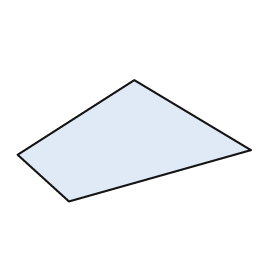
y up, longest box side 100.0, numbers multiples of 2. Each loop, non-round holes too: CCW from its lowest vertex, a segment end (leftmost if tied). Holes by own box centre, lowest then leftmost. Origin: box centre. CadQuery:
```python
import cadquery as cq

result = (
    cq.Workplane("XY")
    .moveTo(-28.0, -26.0)
    .lineTo(50.0, -4.0)
    .lineTo(0.0, 26.0)
    .lineTo(-50.0, -6.0)
    .close()
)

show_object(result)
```